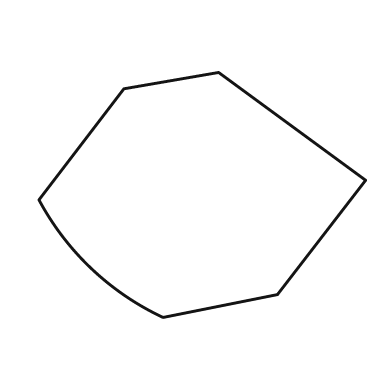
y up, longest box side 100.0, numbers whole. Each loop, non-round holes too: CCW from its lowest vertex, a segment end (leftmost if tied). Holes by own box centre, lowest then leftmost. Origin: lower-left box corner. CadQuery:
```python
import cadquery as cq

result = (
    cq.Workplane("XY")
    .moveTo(38.0, 0.0)
    .lineTo(73.0, 7.0)
    .lineTo(100.0, 42.0)
    .lineTo(55.0, 75.0)
    .lineTo(26.0, 70.0)
    .lineTo(0.0, 36.0)
    .threePointArc((16.0, 15.0), (38.0, 0.0))
    .close()
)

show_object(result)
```